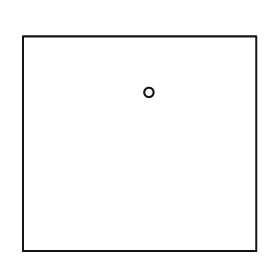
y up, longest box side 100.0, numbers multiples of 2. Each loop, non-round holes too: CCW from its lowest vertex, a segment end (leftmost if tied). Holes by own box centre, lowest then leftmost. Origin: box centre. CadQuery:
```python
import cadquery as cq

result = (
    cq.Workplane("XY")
    .moveTo(-50.0, -46.0)
    .lineTo(50.0, -46.0)
    .lineTo(50.0, 46.0)
    .lineTo(-50.0, 46.0)
    .close()
    .moveTo(4.0, 22.0)
    .circle(2.0)
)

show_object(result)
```